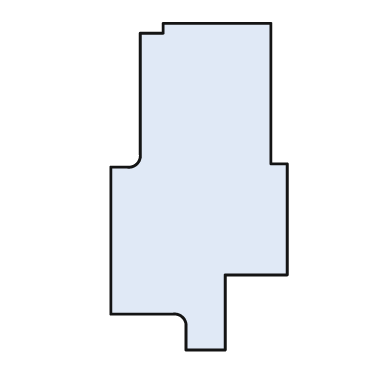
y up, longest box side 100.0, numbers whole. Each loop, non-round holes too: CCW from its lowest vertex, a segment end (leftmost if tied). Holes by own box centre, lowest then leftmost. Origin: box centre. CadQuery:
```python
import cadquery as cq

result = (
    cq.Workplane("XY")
    .moveTo(-4.0, -50.0)
    .lineTo(8.0, -50.0)
    .lineTo(8.0, -27.0)
    .lineTo(27.0, -27.0)
    .lineTo(27.0, 7.0)
    .lineTo(22.0, 7.0)
    .lineTo(22.0, 50.0)
    .lineTo(-11.0, 50.0)
    .lineTo(-11.0, 47.0)
    .lineTo(-18.0, 47.0)
    .lineTo(-18.0, 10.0)
    .threePointArc((-19.0, 7.0), (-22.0, 6.0))
    .lineTo(-27.0, 6.0)
    .lineTo(-27.0, -39.0)
    .lineTo(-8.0, -39.0)
    .threePointArc((-5.0, -40.0), (-4.0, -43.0))
    .close()
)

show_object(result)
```